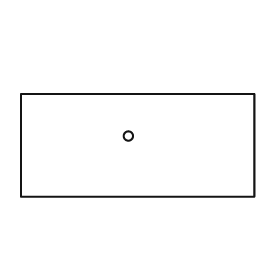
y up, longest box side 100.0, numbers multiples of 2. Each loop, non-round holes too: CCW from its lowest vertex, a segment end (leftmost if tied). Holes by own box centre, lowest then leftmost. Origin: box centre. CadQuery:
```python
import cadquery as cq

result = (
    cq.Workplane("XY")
    .moveTo(-50.0, -22.0)
    .lineTo(50.0, -22.0)
    .lineTo(50.0, 22.0)
    .lineTo(-50.0, 22.0)
    .close()
    .moveTo(-4.0, 4.0)
    .circle(2.0)
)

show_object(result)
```